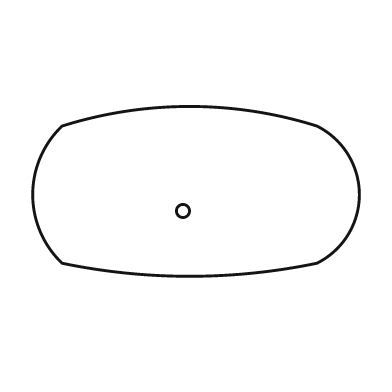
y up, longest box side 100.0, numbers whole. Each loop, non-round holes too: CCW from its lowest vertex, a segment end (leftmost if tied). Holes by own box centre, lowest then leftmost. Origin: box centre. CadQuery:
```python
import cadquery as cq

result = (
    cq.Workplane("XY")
    .moveTo(-41.0, -22.0)
    .threePointArc((-2.0, -26.0), (37.0, -22.0))
    .threePointArc((50.0, -1.0), (37.0, 20.0))
    .threePointArc((-2.0, 26.0), (-41.0, 20.0))
    .threePointArc((-50.0, -1.0), (-41.0, -22.0))
    .close()
    .moveTo(-4.0, -6.0)
    .circle(2.0)
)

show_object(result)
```